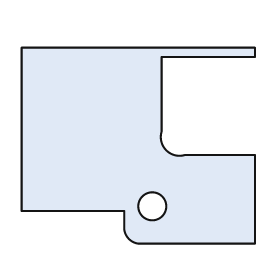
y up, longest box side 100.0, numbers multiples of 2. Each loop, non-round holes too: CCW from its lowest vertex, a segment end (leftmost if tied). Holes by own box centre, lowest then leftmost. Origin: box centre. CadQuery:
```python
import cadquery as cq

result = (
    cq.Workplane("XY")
    .moveTo(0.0, -42.0)
    .lineTo(50.0, -42.0)
    .lineTo(50.0, -4.0)
    .lineTo(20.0, -4.0)
    .threePointArc((12.0, -2.0), (10.0, 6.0))
    .lineTo(10.0, 38.0)
    .lineTo(50.0, 38.0)
    .lineTo(50.0, 42.0)
    .lineTo(-50.0, 42.0)
    .lineTo(-50.0, -28.0)
    .lineTo(-6.0, -28.0)
    .lineTo(-6.0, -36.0)
    .threePointArc((-4.0, -40.0), (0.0, -42.0))
    .close()
    .moveTo(6.0, -26.0)
    .circle(6.0)
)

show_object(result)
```